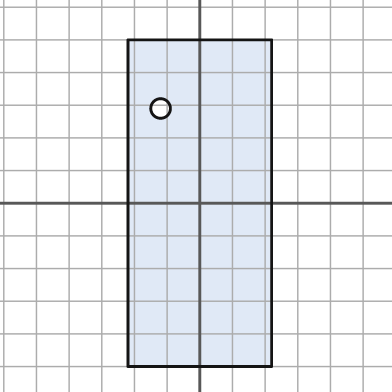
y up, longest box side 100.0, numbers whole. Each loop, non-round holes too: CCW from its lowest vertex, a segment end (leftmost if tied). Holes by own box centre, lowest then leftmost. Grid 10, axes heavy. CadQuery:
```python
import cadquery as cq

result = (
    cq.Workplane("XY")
    .moveTo(-22.0, -50.0)
    .lineTo(22.0, -50.0)
    .lineTo(22.0, 50.0)
    .lineTo(-22.0, 50.0)
    .close()
    .moveTo(-12.0, 29.0)
    .circle(3.0)
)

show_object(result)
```